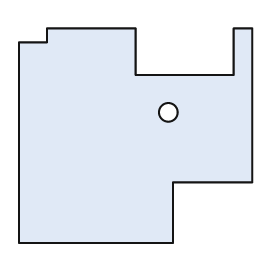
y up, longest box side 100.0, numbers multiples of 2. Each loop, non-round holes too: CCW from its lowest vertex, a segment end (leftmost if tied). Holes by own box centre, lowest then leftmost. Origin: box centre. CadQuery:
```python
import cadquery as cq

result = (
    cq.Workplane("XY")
    .moveTo(-50.0, -46.0)
    .lineTo(16.0, -46.0)
    .lineTo(16.0, -20.0)
    .lineTo(50.0, -20.0)
    .lineTo(50.0, 46.0)
    .lineTo(42.0, 46.0)
    .lineTo(42.0, 26.0)
    .lineTo(0.0, 26.0)
    .lineTo(0.0, 46.0)
    .lineTo(-38.0, 46.0)
    .lineTo(-38.0, 40.0)
    .lineTo(-50.0, 40.0)
    .close()
    .moveTo(14.0, 10.0)
    .circle(4.0)
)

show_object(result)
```